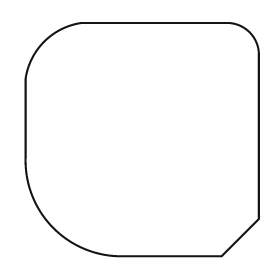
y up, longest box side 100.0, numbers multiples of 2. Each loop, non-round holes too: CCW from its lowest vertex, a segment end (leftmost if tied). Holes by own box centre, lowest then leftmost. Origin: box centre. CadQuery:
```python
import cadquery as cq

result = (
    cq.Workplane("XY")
    .moveTo(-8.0, -50.0)
    .lineTo(34.0, -50.0)
    .lineTo(50.0, -34.0)
    .lineTo(50.0, 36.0)
    .threePointArc((46.0, 46.0), (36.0, 50.0))
    .lineTo(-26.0, 50.0)
    .threePointArc((-42.0, 42.0), (-50.0, 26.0))
    .lineTo(-50.0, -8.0)
    .threePointArc((-38.0, -38.0), (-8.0, -50.0))
    .close()
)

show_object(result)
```